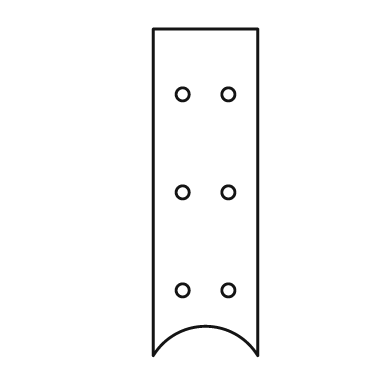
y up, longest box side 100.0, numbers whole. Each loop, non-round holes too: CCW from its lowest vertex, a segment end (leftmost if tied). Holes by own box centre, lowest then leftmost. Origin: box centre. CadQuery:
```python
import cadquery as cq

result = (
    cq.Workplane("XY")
    .moveTo(-16.0, -50.0)
    .threePointArc((0.0, -41.0), (16.0, -50.0))
    .lineTo(16.0, 50.0)
    .lineTo(-16.0, 50.0)
    .close()
    .moveTo(-7.0, -30.0)
    .circle(2.0)
    .moveTo(7.0, -30.0)
    .circle(2.0)
    .moveTo(-7.0, 0.0)
    .circle(2.0)
    .moveTo(7.0, 0.0)
    .circle(2.0)
    .moveTo(-7.0, 30.0)
    .circle(2.0)
    .moveTo(7.0, 30.0)
    .circle(2.0)
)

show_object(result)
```